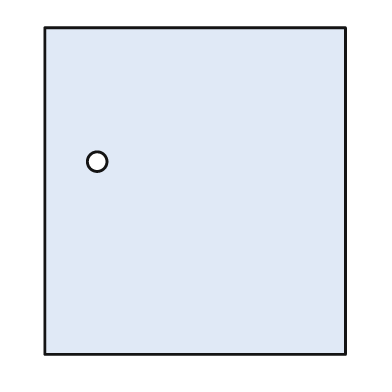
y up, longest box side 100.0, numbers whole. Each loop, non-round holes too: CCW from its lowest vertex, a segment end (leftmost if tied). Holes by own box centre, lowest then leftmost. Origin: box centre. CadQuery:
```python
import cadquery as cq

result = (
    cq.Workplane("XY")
    .moveTo(-46.0, -50.0)
    .lineTo(46.0, -50.0)
    .lineTo(46.0, 50.0)
    .lineTo(-46.0, 50.0)
    .close()
    .moveTo(-30.0, 9.0)
    .circle(3.0)
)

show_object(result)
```